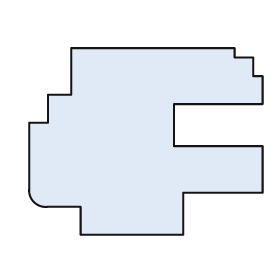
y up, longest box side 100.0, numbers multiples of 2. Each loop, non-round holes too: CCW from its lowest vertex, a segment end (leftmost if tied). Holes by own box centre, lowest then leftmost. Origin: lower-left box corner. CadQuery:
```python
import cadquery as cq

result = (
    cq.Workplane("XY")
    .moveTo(22.0, 0.0)
    .lineTo(66.0, 0.0)
    .lineTo(66.0, 18.0)
    .lineTo(100.0, 18.0)
    .lineTo(100.0, 38.0)
    .lineTo(62.0, 38.0)
    .lineTo(62.0, 56.0)
    .lineTo(100.0, 56.0)
    .lineTo(100.0, 68.0)
    .lineTo(96.0, 68.0)
    .lineTo(96.0, 76.0)
    .lineTo(88.0, 76.0)
    .lineTo(88.0, 80.0)
    .lineTo(18.0, 80.0)
    .lineTo(18.0, 60.0)
    .lineTo(8.0, 60.0)
    .lineTo(8.0, 48.0)
    .lineTo(0.0, 48.0)
    .lineTo(0.0, 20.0)
    .threePointArc((2.0, 14.0), (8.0, 12.0))
    .lineTo(22.0, 12.0)
    .close()
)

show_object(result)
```